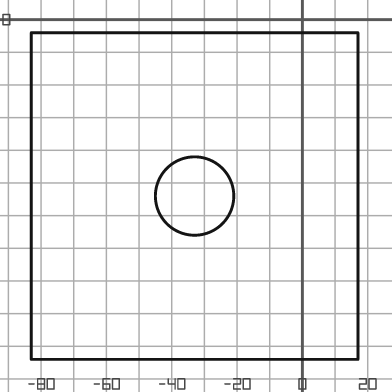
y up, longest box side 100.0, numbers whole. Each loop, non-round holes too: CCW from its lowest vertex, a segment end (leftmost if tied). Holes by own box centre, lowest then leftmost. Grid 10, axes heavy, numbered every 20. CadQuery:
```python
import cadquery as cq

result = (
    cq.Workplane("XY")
    .moveTo(-83.0, -104.0)
    .lineTo(17.0, -104.0)
    .lineTo(17.0, -4.0)
    .lineTo(-83.0, -4.0)
    .close()
    .moveTo(-33.0, -54.0)
    .circle(12.0)
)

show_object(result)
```